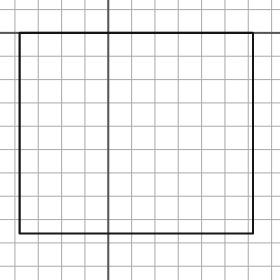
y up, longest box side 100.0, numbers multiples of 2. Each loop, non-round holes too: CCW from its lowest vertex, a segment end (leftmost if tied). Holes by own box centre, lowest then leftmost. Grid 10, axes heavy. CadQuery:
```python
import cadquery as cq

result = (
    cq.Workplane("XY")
    .moveTo(-38.0, -86.0)
    .lineTo(62.0, -86.0)
    .lineTo(62.0, 0.0)
    .lineTo(-38.0, 0.0)
    .close()
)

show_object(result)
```